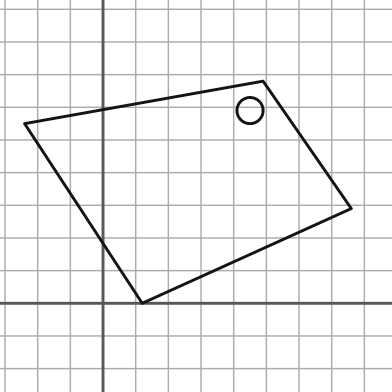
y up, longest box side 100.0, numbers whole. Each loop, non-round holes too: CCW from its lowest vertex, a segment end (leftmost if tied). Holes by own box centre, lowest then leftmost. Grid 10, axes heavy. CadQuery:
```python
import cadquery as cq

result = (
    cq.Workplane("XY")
    .moveTo(12.0, 0.0)
    .lineTo(76.0, 29.0)
    .lineTo(49.0, 68.0)
    .lineTo(-24.0, 55.0)
    .close()
    .moveTo(45.0, 59.0)
    .circle(4.0)
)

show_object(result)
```